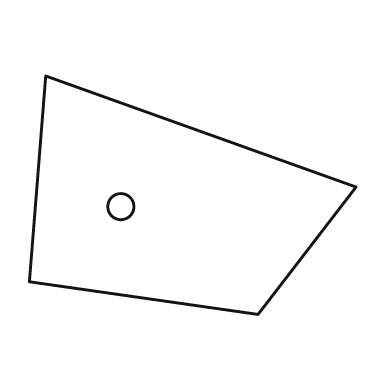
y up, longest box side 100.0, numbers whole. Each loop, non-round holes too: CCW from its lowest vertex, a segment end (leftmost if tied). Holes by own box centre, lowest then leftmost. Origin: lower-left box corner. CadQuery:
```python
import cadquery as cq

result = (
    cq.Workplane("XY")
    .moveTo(70.0, 0.0)
    .lineTo(100.0, 39.0)
    .lineTo(5.0, 73.0)
    .lineTo(0.0, 10.0)
    .close()
    .moveTo(28.0, 33.0)
    .circle(4.0)
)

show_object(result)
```